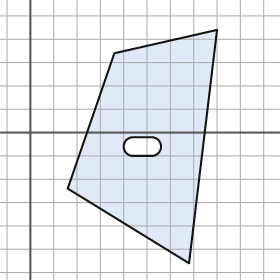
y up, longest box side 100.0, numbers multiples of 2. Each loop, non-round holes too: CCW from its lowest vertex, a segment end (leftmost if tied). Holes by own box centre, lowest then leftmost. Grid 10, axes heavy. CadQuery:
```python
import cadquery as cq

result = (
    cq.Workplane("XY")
    .moveTo(68.0, -56.0)
    .lineTo(80.0, 44.0)
    .lineTo(36.0, 34.0)
    .lineTo(16.0, -24.0)
    .close()
    .moveTo(44.0, -10.0)
    .lineTo(52.0, -10.0)
    .threePointArc((56.0, -6.0), (52.0, -2.0))
    .lineTo(44.0, -2.0)
    .threePointArc((40.0, -6.0), (44.0, -10.0))
    .close()
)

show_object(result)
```